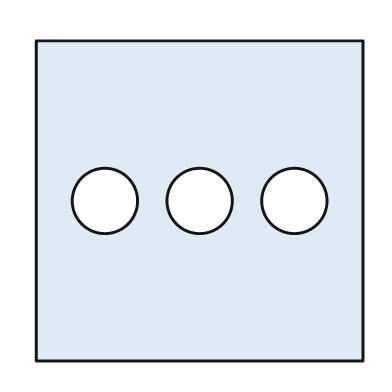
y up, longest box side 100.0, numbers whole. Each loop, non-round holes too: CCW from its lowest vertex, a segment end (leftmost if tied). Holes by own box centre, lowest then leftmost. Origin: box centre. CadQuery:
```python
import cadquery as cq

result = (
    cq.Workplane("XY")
    .moveTo(-50.0, -49.0)
    .lineTo(50.0, -49.0)
    .lineTo(50.0, 49.0)
    .lineTo(-50.0, 49.0)
    .close()
    .moveTo(-29.0, 0.0)
    .circle(10.0)
    .moveTo(0.0, 0.0)
    .circle(10.0)
    .moveTo(29.0, 0.0)
    .circle(10.0)
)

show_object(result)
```